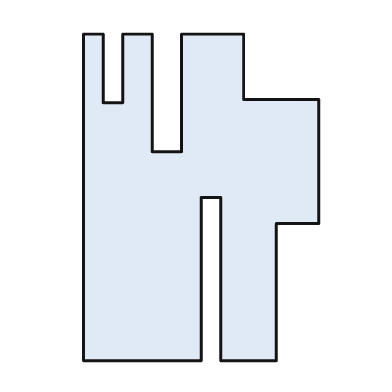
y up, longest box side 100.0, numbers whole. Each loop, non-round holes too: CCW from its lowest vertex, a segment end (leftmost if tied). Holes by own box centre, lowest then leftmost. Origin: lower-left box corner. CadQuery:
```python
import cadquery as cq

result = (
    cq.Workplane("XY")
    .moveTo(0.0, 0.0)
    .lineTo(36.0, 0.0)
    .lineTo(36.0, 50.0)
    .lineTo(42.0, 50.0)
    .lineTo(42.0, 0.0)
    .lineTo(59.0, 0.0)
    .lineTo(59.0, 42.0)
    .lineTo(72.0, 42.0)
    .lineTo(72.0, 80.0)
    .lineTo(49.0, 80.0)
    .lineTo(49.0, 100.0)
    .lineTo(30.0, 100.0)
    .lineTo(30.0, 64.0)
    .lineTo(21.0, 64.0)
    .lineTo(21.0, 100.0)
    .lineTo(12.0, 100.0)
    .lineTo(12.0, 79.0)
    .lineTo(6.0, 79.0)
    .lineTo(6.0, 100.0)
    .lineTo(0.0, 100.0)
    .close()
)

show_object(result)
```